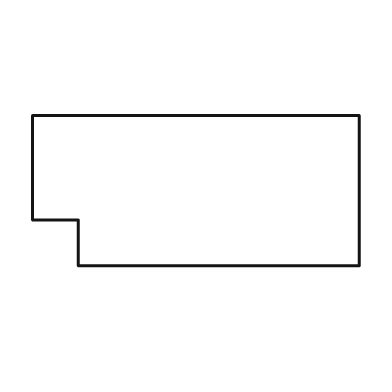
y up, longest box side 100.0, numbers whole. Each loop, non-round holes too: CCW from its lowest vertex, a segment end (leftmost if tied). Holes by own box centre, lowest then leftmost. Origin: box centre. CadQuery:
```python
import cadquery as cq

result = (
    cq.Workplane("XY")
    .moveTo(-36.0, -23.0)
    .lineTo(50.0, -23.0)
    .lineTo(50.0, 23.0)
    .lineTo(-50.0, 23.0)
    .lineTo(-50.0, -9.0)
    .lineTo(-36.0, -9.0)
    .close()
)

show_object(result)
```